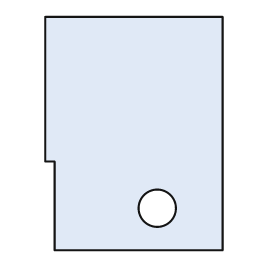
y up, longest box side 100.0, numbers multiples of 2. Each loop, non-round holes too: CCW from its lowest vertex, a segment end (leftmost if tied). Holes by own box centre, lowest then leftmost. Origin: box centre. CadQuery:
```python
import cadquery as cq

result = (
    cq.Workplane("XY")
    .moveTo(-34.0, -50.0)
    .lineTo(38.0, -50.0)
    .lineTo(38.0, 50.0)
    .lineTo(-38.0, 50.0)
    .lineTo(-38.0, -12.0)
    .lineTo(-34.0, -12.0)
    .close()
    .moveTo(10.0, -32.0)
    .circle(8.0)
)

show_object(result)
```